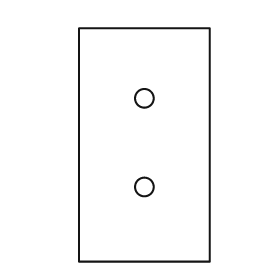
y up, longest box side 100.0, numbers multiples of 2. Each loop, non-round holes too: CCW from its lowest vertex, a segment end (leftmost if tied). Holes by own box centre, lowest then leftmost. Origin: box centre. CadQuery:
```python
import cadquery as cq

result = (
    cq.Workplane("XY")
    .moveTo(-28.0, -50.0)
    .lineTo(28.0, -50.0)
    .lineTo(28.0, 50.0)
    .lineTo(-28.0, 50.0)
    .close()
    .moveTo(0.0, -18.0)
    .circle(4.0)
    .moveTo(0.0, 20.0)
    .circle(4.0)
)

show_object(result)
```